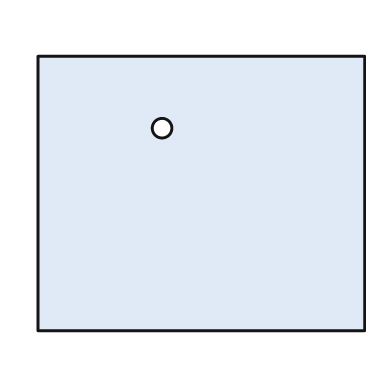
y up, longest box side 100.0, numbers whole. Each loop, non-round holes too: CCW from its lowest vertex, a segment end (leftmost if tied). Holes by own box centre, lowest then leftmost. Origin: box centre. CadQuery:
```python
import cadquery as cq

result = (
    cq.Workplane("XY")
    .moveTo(-50.0, -42.0)
    .lineTo(50.0, -42.0)
    .lineTo(50.0, 42.0)
    .lineTo(-50.0, 42.0)
    .close()
    .moveTo(-12.0, 20.0)
    .circle(3.0)
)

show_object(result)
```